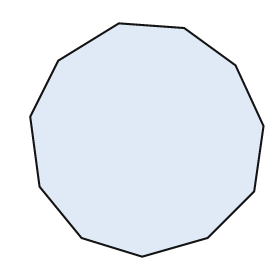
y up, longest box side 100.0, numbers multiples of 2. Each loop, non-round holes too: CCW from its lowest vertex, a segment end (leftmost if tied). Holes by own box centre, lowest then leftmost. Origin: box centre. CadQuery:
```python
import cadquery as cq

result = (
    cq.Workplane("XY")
    .moveTo(-2.0, -50.0)
    .lineTo(26.0, -42.0)
    .lineTo(46.0, -22.0)
    .lineTo(50.0, 6.0)
    .lineTo(38.0, 32.0)
    .lineTo(16.0, 48.0)
    .lineTo(-12.0, 50.0)
    .lineTo(-38.0, 34.0)
    .lineTo(-50.0, 10.0)
    .lineTo(-46.0, -20.0)
    .lineTo(-28.0, -42.0)
    .close()
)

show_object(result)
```